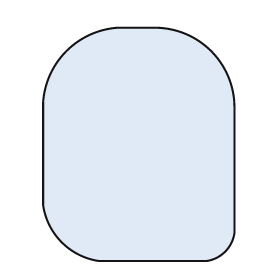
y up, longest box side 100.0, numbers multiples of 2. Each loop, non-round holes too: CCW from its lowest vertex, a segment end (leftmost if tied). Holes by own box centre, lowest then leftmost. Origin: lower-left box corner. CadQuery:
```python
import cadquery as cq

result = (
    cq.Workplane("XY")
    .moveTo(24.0, 0.0)
    .lineTo(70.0, 0.0)
    .threePointArc((78.0, 4.0), (82.0, 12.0))
    .lineTo(82.0, 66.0)
    .threePointArc((72.0, 90.0), (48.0, 100.0))
    .lineTo(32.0, 100.0)
    .threePointArc((10.0, 90.0), (0.0, 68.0))
    .lineTo(0.0, 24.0)
    .threePointArc((8.0, 8.0), (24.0, 0.0))
    .close()
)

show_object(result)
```